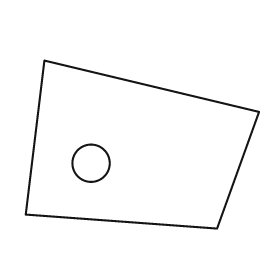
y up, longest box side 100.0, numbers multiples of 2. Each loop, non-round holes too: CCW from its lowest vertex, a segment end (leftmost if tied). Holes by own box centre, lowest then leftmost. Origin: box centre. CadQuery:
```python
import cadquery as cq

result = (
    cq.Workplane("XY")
    .moveTo(32.0, -36.0)
    .lineTo(50.0, 14.0)
    .lineTo(-42.0, 36.0)
    .lineTo(-50.0, -30.0)
    .close()
    .moveTo(-22.0, -8.0)
    .circle(8.0)
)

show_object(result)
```